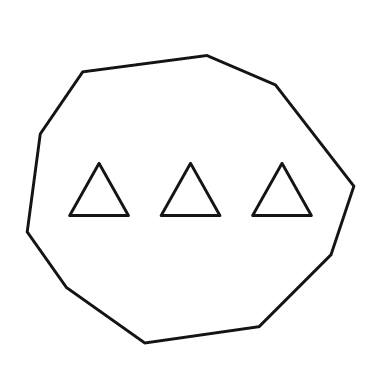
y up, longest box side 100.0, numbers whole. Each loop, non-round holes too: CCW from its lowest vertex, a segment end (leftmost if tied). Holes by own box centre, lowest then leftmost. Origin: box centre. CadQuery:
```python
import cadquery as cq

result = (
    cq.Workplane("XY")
    .moveTo(-14.0, -44.0)
    .lineTo(21.0, -39.0)
    .lineTo(43.0, -17.0)
    .lineTo(50.0, 4.0)
    .lineTo(26.0, 35.0)
    .lineTo(5.0, 44.0)
    .lineTo(-33.0, 39.0)
    .lineTo(-46.0, 20.0)
    .lineTo(-50.0, -10.0)
    .lineTo(-38.0, -27.0)
    .close()
    .moveTo(-37.0, -5.0)
    .lineTo(-19.0, -5.0)
    .lineTo(-28.0, 11.0)
    .close()
    .moveTo(-9.0, -5.0)
    .lineTo(9.0, -5.0)
    .lineTo(0.0, 11.0)
    .close()
    .moveTo(19.0, -5.0)
    .lineTo(37.0, -5.0)
    .lineTo(28.0, 11.0)
    .close()
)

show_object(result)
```